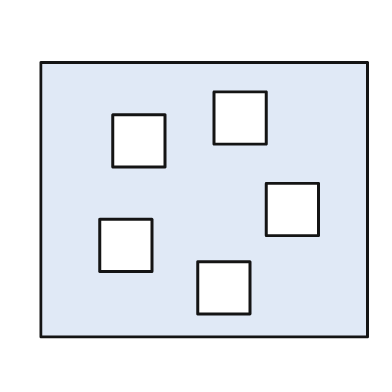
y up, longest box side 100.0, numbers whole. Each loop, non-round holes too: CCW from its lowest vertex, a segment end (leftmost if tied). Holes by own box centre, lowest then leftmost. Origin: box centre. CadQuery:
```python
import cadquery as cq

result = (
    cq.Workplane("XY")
    .moveTo(-50.0, -42.0)
    .lineTo(50.0, -42.0)
    .lineTo(50.0, 42.0)
    .lineTo(-50.0, 42.0)
    .close()
    .moveTo(-2.0, -35.0)
    .lineTo(14.0, -35.0)
    .lineTo(14.0, -19.0)
    .lineTo(-2.0, -19.0)
    .close()
    .moveTo(-32.0, -22.0)
    .lineTo(-16.0, -22.0)
    .lineTo(-16.0, -6.0)
    .lineTo(-32.0, -6.0)
    .close()
    .moveTo(19.0, -11.0)
    .lineTo(35.0, -11.0)
    .lineTo(35.0, 5.0)
    .lineTo(19.0, 5.0)
    .close()
    .moveTo(-28.0, 10.0)
    .lineTo(-12.0, 10.0)
    .lineTo(-12.0, 26.0)
    .lineTo(-28.0, 26.0)
    .close()
    .moveTo(3.0, 17.0)
    .lineTo(19.0, 17.0)
    .lineTo(19.0, 33.0)
    .lineTo(3.0, 33.0)
    .close()
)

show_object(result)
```